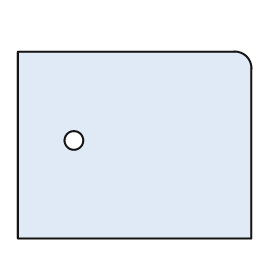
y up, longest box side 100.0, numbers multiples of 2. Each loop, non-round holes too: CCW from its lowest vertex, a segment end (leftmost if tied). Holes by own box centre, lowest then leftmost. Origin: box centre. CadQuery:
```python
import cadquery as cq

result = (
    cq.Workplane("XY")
    .moveTo(-50.0, -40.0)
    .lineTo(50.0, -40.0)
    .lineTo(50.0, 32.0)
    .threePointArc((48.0, 38.0), (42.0, 40.0))
    .lineTo(-50.0, 40.0)
    .close()
    .moveTo(-26.0, 2.0)
    .circle(4.0)
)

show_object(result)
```